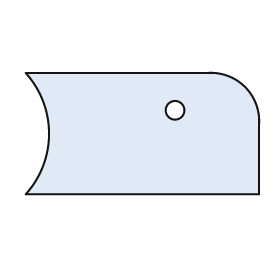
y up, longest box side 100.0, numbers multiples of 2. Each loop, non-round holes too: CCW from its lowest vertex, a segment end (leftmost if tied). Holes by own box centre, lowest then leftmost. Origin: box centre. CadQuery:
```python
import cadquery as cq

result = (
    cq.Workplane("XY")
    .moveTo(-50.0, -26.0)
    .lineTo(50.0, -26.0)
    .lineTo(50.0, 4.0)
    .threePointArc((44.0, 20.0), (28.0, 26.0))
    .lineTo(-50.0, 26.0)
    .threePointArc((-40.0, 0.0), (-50.0, -26.0))
    .close()
    .moveTo(14.0, 10.0)
    .circle(4.0)
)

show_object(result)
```